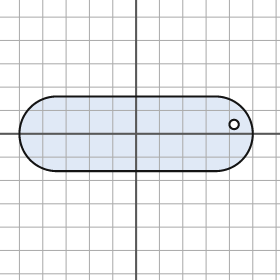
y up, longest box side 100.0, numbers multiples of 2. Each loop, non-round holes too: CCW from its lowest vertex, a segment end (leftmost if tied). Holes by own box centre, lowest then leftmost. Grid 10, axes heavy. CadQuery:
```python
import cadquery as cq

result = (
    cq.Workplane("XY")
    .moveTo(-34.0, -16.0)
    .lineTo(34.0, -16.0)
    .threePointArc((50.0, 0.0), (34.0, 16.0))
    .lineTo(-34.0, 16.0)
    .threePointArc((-50.0, 0.0), (-34.0, -16.0))
    .close()
    .moveTo(42.0, 4.0)
    .circle(2.0)
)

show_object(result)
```